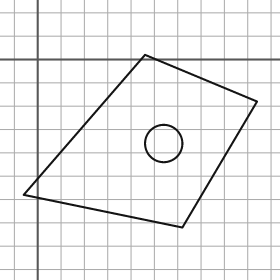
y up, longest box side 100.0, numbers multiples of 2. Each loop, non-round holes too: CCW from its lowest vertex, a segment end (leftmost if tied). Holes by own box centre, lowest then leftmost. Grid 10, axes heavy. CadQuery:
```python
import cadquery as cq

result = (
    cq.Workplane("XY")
    .moveTo(62.0, -72.0)
    .lineTo(94.0, -18.0)
    .lineTo(46.0, 2.0)
    .lineTo(-6.0, -58.0)
    .close()
    .moveTo(54.0, -36.0)
    .circle(8.0)
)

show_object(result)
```